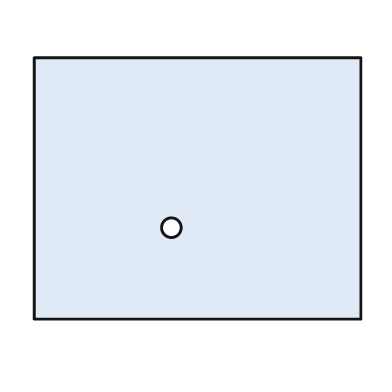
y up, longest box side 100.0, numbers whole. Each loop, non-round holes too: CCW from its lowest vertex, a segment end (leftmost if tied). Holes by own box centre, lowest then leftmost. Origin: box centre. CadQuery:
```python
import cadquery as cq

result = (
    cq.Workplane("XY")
    .moveTo(-50.0, -40.0)
    .lineTo(50.0, -40.0)
    .lineTo(50.0, 40.0)
    .lineTo(-50.0, 40.0)
    .close()
    .moveTo(-8.0, -12.0)
    .circle(3.0)
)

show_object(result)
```